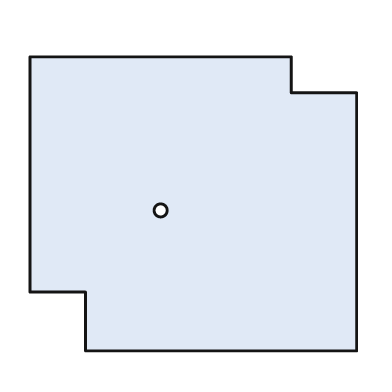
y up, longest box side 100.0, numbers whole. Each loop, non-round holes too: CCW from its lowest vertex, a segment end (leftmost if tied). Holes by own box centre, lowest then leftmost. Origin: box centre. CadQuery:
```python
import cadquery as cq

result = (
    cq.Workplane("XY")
    .moveTo(-33.0, -45.0)
    .lineTo(50.0, -45.0)
    .lineTo(50.0, 34.0)
    .lineTo(30.0, 34.0)
    .lineTo(30.0, 45.0)
    .lineTo(-50.0, 45.0)
    .lineTo(-50.0, -27.0)
    .lineTo(-33.0, -27.0)
    .close()
    .moveTo(-10.0, -2.0)
    .circle(2.0)
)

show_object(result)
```